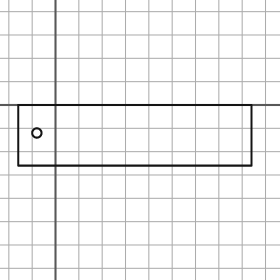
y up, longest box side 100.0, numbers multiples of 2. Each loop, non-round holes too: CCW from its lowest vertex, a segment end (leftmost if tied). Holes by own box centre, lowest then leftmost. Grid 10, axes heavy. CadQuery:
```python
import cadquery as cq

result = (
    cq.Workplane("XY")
    .moveTo(-16.0, -26.0)
    .lineTo(84.0, -26.0)
    .lineTo(84.0, 0.0)
    .lineTo(-16.0, 0.0)
    .close()
    .moveTo(-8.0, -12.0)
    .circle(2.0)
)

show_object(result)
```